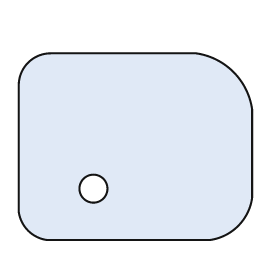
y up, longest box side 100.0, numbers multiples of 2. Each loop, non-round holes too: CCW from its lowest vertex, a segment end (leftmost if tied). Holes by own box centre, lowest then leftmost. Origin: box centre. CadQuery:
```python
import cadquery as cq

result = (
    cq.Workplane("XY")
    .moveTo(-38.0, -40.0)
    .lineTo(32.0, -40.0)
    .threePointArc((44.0, -34.0), (50.0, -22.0))
    .lineTo(50.0, 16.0)
    .threePointArc((42.0, 32.0), (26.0, 40.0))
    .lineTo(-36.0, 40.0)
    .threePointArc((-46.0, 36.0), (-50.0, 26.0))
    .lineTo(-50.0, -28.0)
    .threePointArc((-46.0, -36.0), (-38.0, -40.0))
    .close()
    .moveTo(-18.0, -18.0)
    .circle(6.0)
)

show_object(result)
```